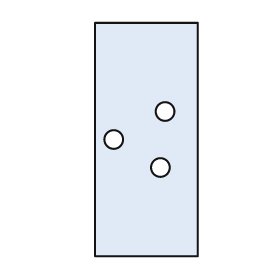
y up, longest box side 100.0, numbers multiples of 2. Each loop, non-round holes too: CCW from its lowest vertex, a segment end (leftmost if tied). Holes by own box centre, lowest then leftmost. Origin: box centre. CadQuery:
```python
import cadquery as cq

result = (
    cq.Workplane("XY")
    .moveTo(-22.0, -50.0)
    .lineTo(22.0, -50.0)
    .lineTo(22.0, 50.0)
    .lineTo(-22.0, 50.0)
    .close()
    .moveTo(6.0, -12.0)
    .circle(4.0)
    .moveTo(-14.0, 0.0)
    .circle(4.0)
    .moveTo(8.0, 12.0)
    .circle(4.0)
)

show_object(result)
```